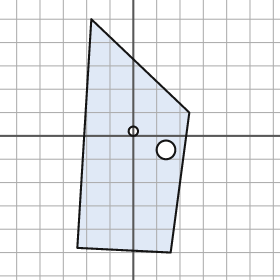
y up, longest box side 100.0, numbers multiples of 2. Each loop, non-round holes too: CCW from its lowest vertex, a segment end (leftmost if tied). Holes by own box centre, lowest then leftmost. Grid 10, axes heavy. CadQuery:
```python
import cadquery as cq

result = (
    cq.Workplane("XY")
    .moveTo(16.0, -50.0)
    .lineTo(24.0, 10.0)
    .lineTo(-18.0, 50.0)
    .lineTo(-24.0, -48.0)
    .close()
    .moveTo(14.0, -6.0)
    .circle(4.0)
    .moveTo(0.0, 2.0)
    .circle(2.0)
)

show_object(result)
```